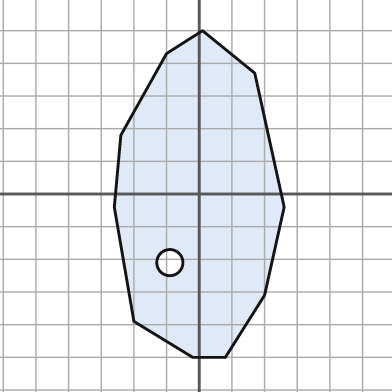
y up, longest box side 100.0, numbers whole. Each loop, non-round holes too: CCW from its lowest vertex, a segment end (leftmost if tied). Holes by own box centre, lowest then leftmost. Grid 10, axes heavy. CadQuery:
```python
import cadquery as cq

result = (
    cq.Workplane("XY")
    .moveTo(-2.0, -50.0)
    .lineTo(8.0, -50.0)
    .lineTo(20.0, -31.0)
    .lineTo(26.0, -4.0)
    .lineTo(17.0, 37.0)
    .lineTo(1.0, 50.0)
    .lineTo(-10.0, 43.0)
    .lineTo(-24.0, 18.0)
    .lineTo(-26.0, -4.0)
    .lineTo(-20.0, -39.0)
    .close()
    .moveTo(-9.0, -21.0)
    .circle(4.0)
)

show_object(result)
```